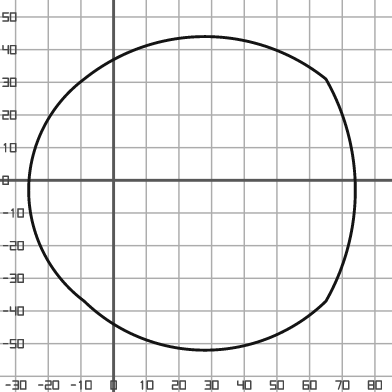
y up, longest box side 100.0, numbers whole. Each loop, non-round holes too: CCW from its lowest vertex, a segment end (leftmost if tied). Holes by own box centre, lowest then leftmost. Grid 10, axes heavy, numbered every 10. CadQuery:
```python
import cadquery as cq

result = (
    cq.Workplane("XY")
    .moveTo(-9.0, -37.0)
    .threePointArc((28.0, -52.0), (65.0, -37.0))
    .threePointArc((74.0, -3.0), (65.0, 31.0))
    .threePointArc((28.0, 44.0), (-9.0, 31.0))
    .threePointArc((-26.0, -3.0), (-9.0, -37.0))
    .close()
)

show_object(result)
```